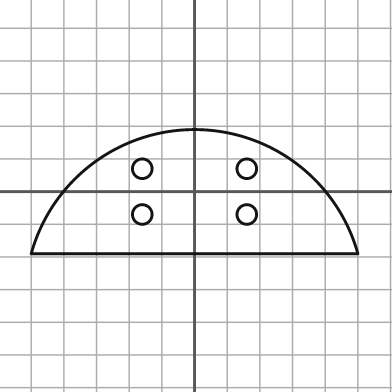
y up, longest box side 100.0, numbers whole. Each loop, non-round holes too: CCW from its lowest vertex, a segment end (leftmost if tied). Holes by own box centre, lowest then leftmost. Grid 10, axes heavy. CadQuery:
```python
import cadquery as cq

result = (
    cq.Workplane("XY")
    .moveTo(-50.0, -19.0)
    .lineTo(50.0, -19.0)
    .threePointArc((0.0, 19.0), (-50.0, -19.0))
    .close()
    .moveTo(-16.0, -7.0)
    .circle(3.0)
    .moveTo(16.0, -7.0)
    .circle(3.0)
    .moveTo(-16.0, 7.0)
    .circle(3.0)
    .moveTo(16.0, 7.0)
    .circle(3.0)
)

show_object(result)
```